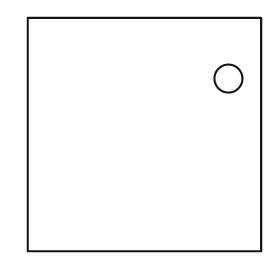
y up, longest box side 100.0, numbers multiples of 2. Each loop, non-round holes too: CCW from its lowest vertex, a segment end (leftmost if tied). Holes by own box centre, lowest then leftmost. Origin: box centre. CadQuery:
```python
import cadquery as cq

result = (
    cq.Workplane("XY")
    .moveTo(-50.0, -50.0)
    .lineTo(50.0, -50.0)
    .lineTo(50.0, 50.0)
    .lineTo(-50.0, 50.0)
    .close()
    .moveTo(36.0, 24.0)
    .circle(6.0)
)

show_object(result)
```